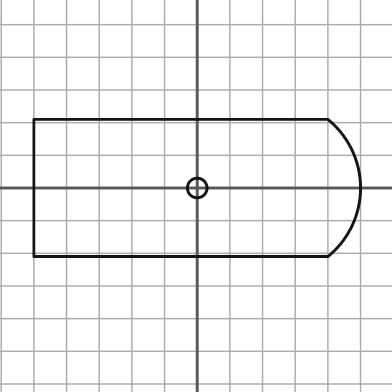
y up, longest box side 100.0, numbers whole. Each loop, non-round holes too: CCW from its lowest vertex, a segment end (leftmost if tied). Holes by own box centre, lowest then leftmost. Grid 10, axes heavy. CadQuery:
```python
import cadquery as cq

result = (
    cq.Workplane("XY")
    .moveTo(-50.0, -21.0)
    .lineTo(40.0, -21.0)
    .threePointArc((50.0, 0.0), (40.0, 21.0))
    .lineTo(-50.0, 21.0)
    .close()
    .moveTo(0.0, 0.0)
    .circle(3.0)
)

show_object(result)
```